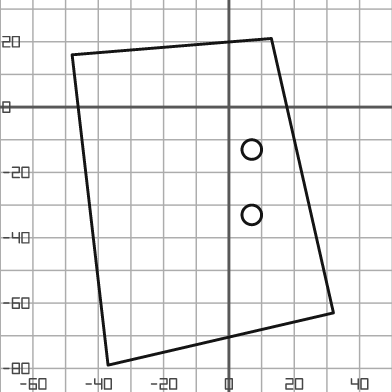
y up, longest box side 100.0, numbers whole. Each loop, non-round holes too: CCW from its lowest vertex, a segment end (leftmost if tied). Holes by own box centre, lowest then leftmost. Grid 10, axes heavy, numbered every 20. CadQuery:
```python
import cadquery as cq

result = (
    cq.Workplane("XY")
    .moveTo(-37.0, -79.0)
    .lineTo(32.0, -63.0)
    .lineTo(13.0, 21.0)
    .lineTo(-48.0, 16.0)
    .close()
    .moveTo(7.0, -33.0)
    .circle(3.0)
    .moveTo(7.0, -13.0)
    .circle(3.0)
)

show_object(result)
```